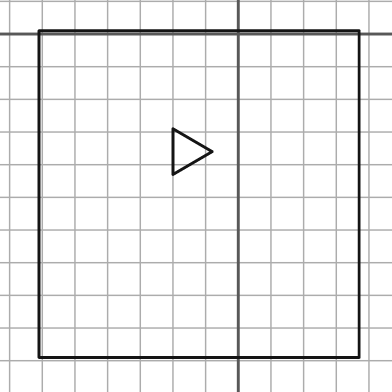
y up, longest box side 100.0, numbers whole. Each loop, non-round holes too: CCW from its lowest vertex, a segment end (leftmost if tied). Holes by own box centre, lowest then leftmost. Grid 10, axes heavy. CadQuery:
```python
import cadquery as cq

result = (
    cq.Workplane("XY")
    .moveTo(-61.0, -99.0)
    .lineTo(37.0, -99.0)
    .lineTo(37.0, 1.0)
    .lineTo(-61.0, 1.0)
    .close()
    .moveTo(-20.0, -43.0)
    .lineTo(-8.0, -36.0)
    .lineTo(-20.0, -29.0)
    .close()
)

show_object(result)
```